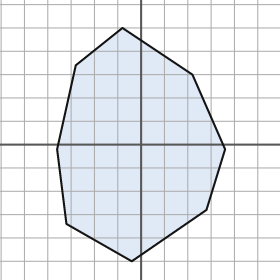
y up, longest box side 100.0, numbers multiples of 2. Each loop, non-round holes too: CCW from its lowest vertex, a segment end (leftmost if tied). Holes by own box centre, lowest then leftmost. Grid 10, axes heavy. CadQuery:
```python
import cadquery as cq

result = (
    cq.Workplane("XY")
    .moveTo(-4.0, -50.0)
    .lineTo(28.0, -28.0)
    .lineTo(36.0, -2.0)
    .lineTo(22.0, 30.0)
    .lineTo(-8.0, 50.0)
    .lineTo(-28.0, 34.0)
    .lineTo(-36.0, -2.0)
    .lineTo(-32.0, -34.0)
    .close()
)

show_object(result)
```